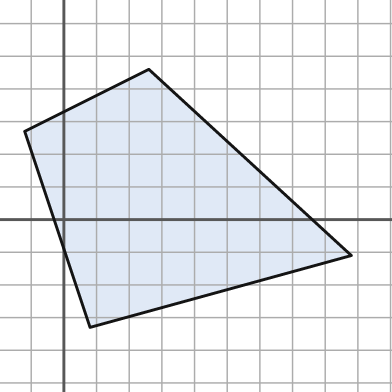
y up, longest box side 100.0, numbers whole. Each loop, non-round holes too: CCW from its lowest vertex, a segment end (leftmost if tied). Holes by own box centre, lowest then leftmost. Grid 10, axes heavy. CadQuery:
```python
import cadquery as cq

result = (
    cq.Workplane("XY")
    .moveTo(8.0, -33.0)
    .lineTo(88.0, -11.0)
    .lineTo(26.0, 46.0)
    .lineTo(-12.0, 27.0)
    .close()
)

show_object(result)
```